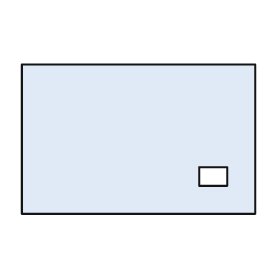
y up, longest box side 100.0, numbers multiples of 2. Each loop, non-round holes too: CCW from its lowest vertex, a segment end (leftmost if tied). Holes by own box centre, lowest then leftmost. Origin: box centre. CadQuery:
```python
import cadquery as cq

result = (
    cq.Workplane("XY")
    .moveTo(-50.0, -32.0)
    .lineTo(50.0, -32.0)
    .lineTo(50.0, 32.0)
    .lineTo(-50.0, 32.0)
    .close()
    .moveTo(26.0, -20.0)
    .lineTo(38.0, -20.0)
    .lineTo(38.0, -12.0)
    .lineTo(26.0, -12.0)
    .close()
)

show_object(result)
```